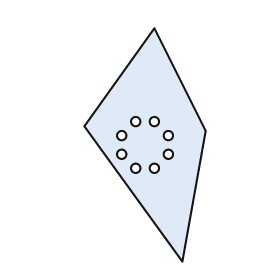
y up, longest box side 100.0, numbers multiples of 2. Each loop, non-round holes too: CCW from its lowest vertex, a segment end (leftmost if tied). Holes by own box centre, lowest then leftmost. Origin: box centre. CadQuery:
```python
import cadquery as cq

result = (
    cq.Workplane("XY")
    .moveTo(16.0, -50.0)
    .lineTo(26.0, 6.0)
    .lineTo(4.0, 50.0)
    .lineTo(-26.0, 8.0)
    .close()
    .moveTo(-4.0, -10.0)
    .circle(2.0)
    .moveTo(4.0, -10.0)
    .circle(2.0)
    .moveTo(-10.0, -4.0)
    .circle(2.0)
    .moveTo(10.0, -4.0)
    .circle(2.0)
    .moveTo(-10.0, 4.0)
    .circle(2.0)
    .moveTo(10.0, 4.0)
    .circle(2.0)
    .moveTo(-4.0, 10.0)
    .circle(2.0)
    .moveTo(4.0, 10.0)
    .circle(2.0)
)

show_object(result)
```